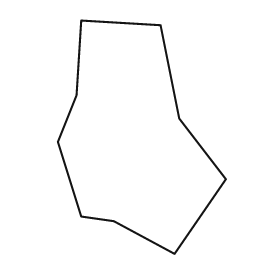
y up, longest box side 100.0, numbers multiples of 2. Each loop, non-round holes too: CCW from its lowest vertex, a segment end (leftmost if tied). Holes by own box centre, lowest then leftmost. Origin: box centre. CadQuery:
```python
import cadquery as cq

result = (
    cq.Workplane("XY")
    .moveTo(14.0, -50.0)
    .lineTo(36.0, -18.0)
    .lineTo(16.0, 8.0)
    .lineTo(8.0, 48.0)
    .lineTo(-26.0, 50.0)
    .lineTo(-28.0, 18.0)
    .lineTo(-36.0, -2.0)
    .lineTo(-26.0, -34.0)
    .lineTo(-12.0, -36.0)
    .close()
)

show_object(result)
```